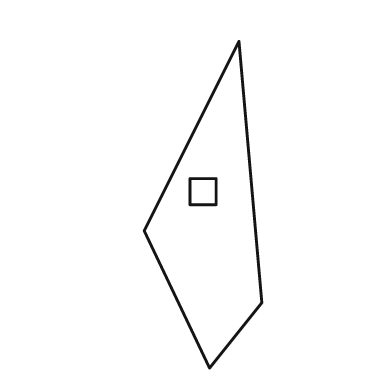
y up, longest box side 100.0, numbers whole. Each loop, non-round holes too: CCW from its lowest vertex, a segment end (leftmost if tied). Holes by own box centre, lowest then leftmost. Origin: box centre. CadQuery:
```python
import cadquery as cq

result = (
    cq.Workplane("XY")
    .moveTo(2.0, -50.0)
    .lineTo(18.0, -30.0)
    .lineTo(11.0, 50.0)
    .lineTo(-18.0, -8.0)
    .close()
    .moveTo(-4.0, 0.0)
    .lineTo(4.0, 0.0)
    .lineTo(4.0, 8.0)
    .lineTo(-4.0, 8.0)
    .close()
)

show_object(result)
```